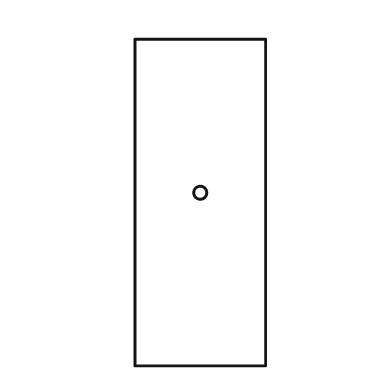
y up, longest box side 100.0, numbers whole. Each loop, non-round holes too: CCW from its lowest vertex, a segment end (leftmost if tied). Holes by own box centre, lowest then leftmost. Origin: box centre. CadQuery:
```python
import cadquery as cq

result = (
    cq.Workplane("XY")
    .moveTo(-20.0, -50.0)
    .lineTo(20.0, -50.0)
    .lineTo(20.0, 50.0)
    .lineTo(-20.0, 50.0)
    .close()
    .moveTo(0.0, 3.0)
    .circle(2.0)
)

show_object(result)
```